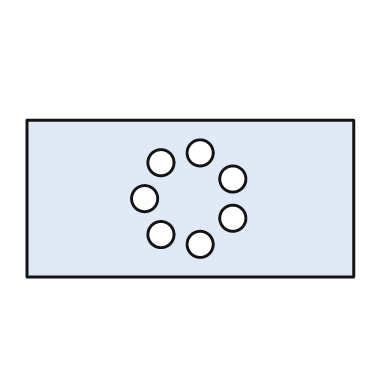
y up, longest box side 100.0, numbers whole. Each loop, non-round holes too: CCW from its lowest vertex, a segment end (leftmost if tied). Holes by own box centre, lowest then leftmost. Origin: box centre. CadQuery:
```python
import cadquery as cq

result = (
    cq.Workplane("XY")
    .moveTo(-50.0, -24.0)
    .lineTo(50.0, -24.0)
    .lineTo(50.0, 24.0)
    .lineTo(-50.0, 24.0)
    .close()
    .moveTo(3.0, -14.0)
    .circle(4.0)
    .moveTo(-9.0, -11.0)
    .circle(4.0)
    .moveTo(13.0, -6.0)
    .circle(4.0)
    .moveTo(-14.0, 0.0)
    .circle(4.0)
    .moveTo(13.0, 6.0)
    .circle(4.0)
    .moveTo(-9.0, 11.0)
    .circle(4.0)
    .moveTo(3.0, 14.0)
    .circle(4.0)
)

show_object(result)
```